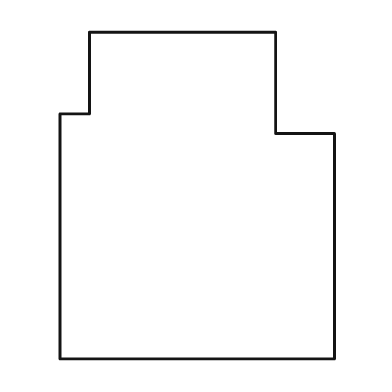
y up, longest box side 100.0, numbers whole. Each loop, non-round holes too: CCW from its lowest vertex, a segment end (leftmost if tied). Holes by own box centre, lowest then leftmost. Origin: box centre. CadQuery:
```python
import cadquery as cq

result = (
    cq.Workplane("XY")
    .moveTo(-42.0, -50.0)
    .lineTo(42.0, -50.0)
    .lineTo(42.0, 19.0)
    .lineTo(24.0, 19.0)
    .lineTo(24.0, 50.0)
    .lineTo(-33.0, 50.0)
    .lineTo(-33.0, 25.0)
    .lineTo(-42.0, 25.0)
    .close()
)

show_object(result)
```